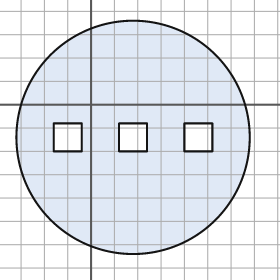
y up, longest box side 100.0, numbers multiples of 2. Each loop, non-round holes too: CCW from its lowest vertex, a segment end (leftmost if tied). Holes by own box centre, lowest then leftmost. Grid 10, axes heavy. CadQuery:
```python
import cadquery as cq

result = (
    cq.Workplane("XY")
    .moveTo(18.0, -14.0)
    .circle(50.0)
    .moveTo(-16.0, -20.0)
    .lineTo(-4.0, -20.0)
    .lineTo(-4.0, -8.0)
    .lineTo(-16.0, -8.0)
    .close()
    .moveTo(12.0, -20.0)
    .lineTo(24.0, -20.0)
    .lineTo(24.0, -8.0)
    .lineTo(12.0, -8.0)
    .close()
    .moveTo(40.0, -20.0)
    .lineTo(52.0, -20.0)
    .lineTo(52.0, -8.0)
    .lineTo(40.0, -8.0)
    .close()
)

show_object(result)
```